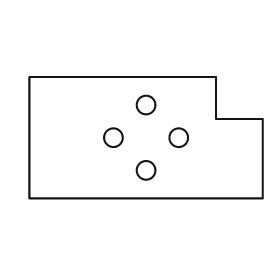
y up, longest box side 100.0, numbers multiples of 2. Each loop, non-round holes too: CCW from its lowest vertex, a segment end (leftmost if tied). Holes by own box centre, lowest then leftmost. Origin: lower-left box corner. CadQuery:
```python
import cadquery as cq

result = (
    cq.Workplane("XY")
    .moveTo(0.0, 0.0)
    .lineTo(100.0, 0.0)
    .lineTo(100.0, 34.0)
    .lineTo(80.0, 34.0)
    .lineTo(80.0, 52.0)
    .lineTo(0.0, 52.0)
    .close()
    .moveTo(50.0, 12.0)
    .circle(4.0)
    .moveTo(36.0, 26.0)
    .circle(4.0)
    .moveTo(64.0, 26.0)
    .circle(4.0)
    .moveTo(50.0, 40.0)
    .circle(4.0)
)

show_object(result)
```